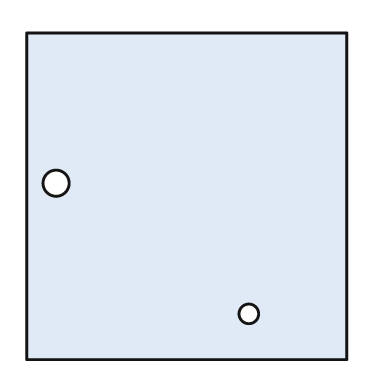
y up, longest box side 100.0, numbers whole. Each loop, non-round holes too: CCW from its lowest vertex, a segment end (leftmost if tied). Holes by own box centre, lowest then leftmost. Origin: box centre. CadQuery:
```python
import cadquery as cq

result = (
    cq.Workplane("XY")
    .moveTo(-49.0, -50.0)
    .lineTo(49.0, -50.0)
    .lineTo(49.0, 50.0)
    .lineTo(-49.0, 50.0)
    .close()
    .moveTo(19.0, -36.0)
    .circle(3.0)
    .moveTo(-40.0, 4.0)
    .circle(4.0)
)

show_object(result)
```